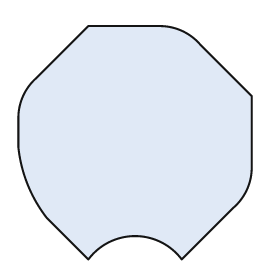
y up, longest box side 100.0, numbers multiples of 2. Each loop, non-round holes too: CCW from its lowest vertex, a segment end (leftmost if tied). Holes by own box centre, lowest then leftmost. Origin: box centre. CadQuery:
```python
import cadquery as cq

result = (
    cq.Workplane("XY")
    .moveTo(-20.0, -50.0)
    .threePointArc((0.0, -40.0), (20.0, -50.0))
    .lineTo(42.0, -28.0)
    .threePointArc((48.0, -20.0), (50.0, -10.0))
    .lineTo(50.0, 20.0)
    .lineTo(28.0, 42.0)
    .threePointArc((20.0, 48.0), (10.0, 50.0))
    .lineTo(-20.0, 50.0)
    .lineTo(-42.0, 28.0)
    .threePointArc((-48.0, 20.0), (-50.0, 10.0))
    .lineTo(-50.0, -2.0)
    .threePointArc((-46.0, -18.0), (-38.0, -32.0))
    .close()
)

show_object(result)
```